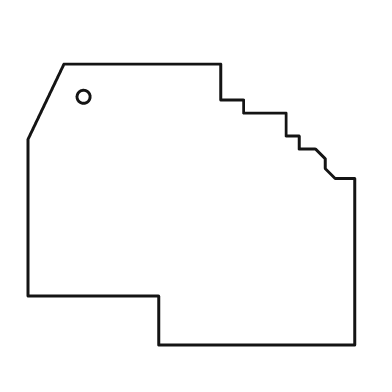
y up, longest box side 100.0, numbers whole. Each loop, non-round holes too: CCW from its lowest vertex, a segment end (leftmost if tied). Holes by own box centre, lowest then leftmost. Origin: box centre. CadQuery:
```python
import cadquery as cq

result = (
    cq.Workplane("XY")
    .moveTo(-10.0, -43.0)
    .lineTo(50.0, -43.0)
    .lineTo(50.0, 8.0)
    .lineTo(44.0, 8.0)
    .lineTo(41.0, 11.0)
    .lineTo(41.0, 14.0)
    .lineTo(38.0, 17.0)
    .lineTo(33.0, 17.0)
    .lineTo(33.0, 21.0)
    .lineTo(29.0, 21.0)
    .lineTo(29.0, 28.0)
    .lineTo(16.0, 28.0)
    .lineTo(16.0, 32.0)
    .lineTo(9.0, 32.0)
    .lineTo(9.0, 43.0)
    .lineTo(-39.0, 43.0)
    .lineTo(-50.0, 20.0)
    .lineTo(-50.0, -28.0)
    .lineTo(-10.0, -28.0)
    .close()
    .moveTo(-33.0, 33.0)
    .circle(2.0)
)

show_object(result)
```